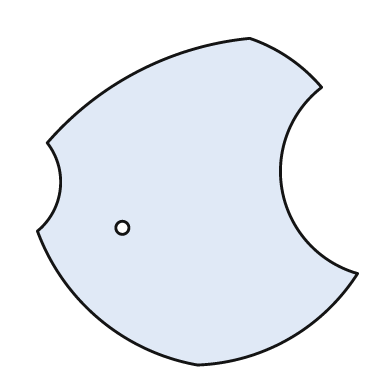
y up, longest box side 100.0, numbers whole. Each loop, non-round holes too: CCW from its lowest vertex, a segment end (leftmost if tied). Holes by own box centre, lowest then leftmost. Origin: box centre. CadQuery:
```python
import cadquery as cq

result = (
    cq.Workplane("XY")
    .moveTo(0.0, -50.0)
    .threePointArc((28.0, -42.0), (49.0, -22.0))
    .threePointArc((26.0, 3.0), (38.0, 35.0))
    .threePointArc((28.0, 44.0), (16.0, 50.0))
    .threePointArc((-18.0, 40.0), (-46.0, 18.0))
    .threePointArc((-42.0, 4.0), (-49.0, -9.0))
    .threePointArc((-30.0, -36.0), (0.0, -50.0))
    .close()
    .moveTo(-23.0, -8.0)
    .circle(2.0)
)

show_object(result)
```